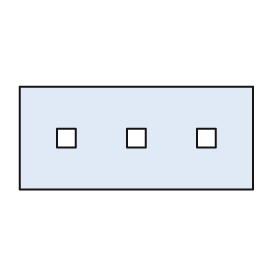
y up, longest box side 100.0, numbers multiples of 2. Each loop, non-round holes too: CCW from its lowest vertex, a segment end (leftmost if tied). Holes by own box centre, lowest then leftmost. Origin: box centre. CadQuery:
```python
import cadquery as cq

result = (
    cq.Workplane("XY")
    .moveTo(-50.0, -22.0)
    .lineTo(50.0, -22.0)
    .lineTo(50.0, 22.0)
    .lineTo(-50.0, 22.0)
    .close()
    .moveTo(-34.0, -4.0)
    .lineTo(-26.0, -4.0)
    .lineTo(-26.0, 4.0)
    .lineTo(-34.0, 4.0)
    .close()
    .moveTo(-4.0, -4.0)
    .lineTo(4.0, -4.0)
    .lineTo(4.0, 4.0)
    .lineTo(-4.0, 4.0)
    .close()
    .moveTo(26.0, -4.0)
    .lineTo(34.0, -4.0)
    .lineTo(34.0, 4.0)
    .lineTo(26.0, 4.0)
    .close()
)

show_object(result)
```